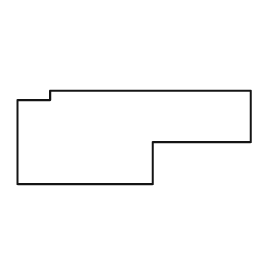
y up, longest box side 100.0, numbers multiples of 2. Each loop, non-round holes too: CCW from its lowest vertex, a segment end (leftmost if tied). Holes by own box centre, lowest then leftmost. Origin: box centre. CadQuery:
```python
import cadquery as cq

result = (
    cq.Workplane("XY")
    .moveTo(-50.0, -20.0)
    .lineTo(8.0, -20.0)
    .lineTo(8.0, -2.0)
    .lineTo(50.0, -2.0)
    .lineTo(50.0, 20.0)
    .lineTo(-36.0, 20.0)
    .lineTo(-36.0, 16.0)
    .lineTo(-50.0, 16.0)
    .close()
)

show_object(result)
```